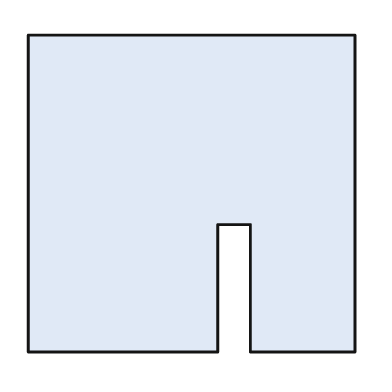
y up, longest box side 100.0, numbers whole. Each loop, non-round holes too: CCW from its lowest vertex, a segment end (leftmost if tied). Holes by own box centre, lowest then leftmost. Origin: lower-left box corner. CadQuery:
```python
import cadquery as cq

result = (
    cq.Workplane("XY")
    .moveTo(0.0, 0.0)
    .lineTo(58.0, 0.0)
    .lineTo(58.0, 39.0)
    .lineTo(68.0, 39.0)
    .lineTo(68.0, 0.0)
    .lineTo(100.0, 0.0)
    .lineTo(100.0, 97.0)
    .lineTo(0.0, 97.0)
    .close()
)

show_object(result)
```